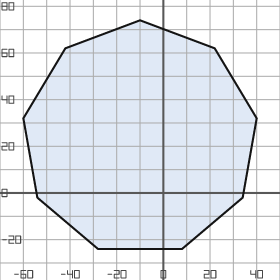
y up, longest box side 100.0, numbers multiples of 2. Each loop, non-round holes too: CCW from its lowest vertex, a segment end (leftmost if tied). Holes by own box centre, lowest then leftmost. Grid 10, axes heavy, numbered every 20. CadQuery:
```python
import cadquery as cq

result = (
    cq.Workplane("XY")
    .moveTo(-28.0, -24.0)
    .lineTo(8.0, -24.0)
    .lineTo(34.0, -2.0)
    .lineTo(40.0, 32.0)
    .lineTo(22.0, 62.0)
    .lineTo(-10.0, 74.0)
    .lineTo(-42.0, 62.0)
    .lineTo(-60.0, 32.0)
    .lineTo(-54.0, -2.0)
    .close()
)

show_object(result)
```